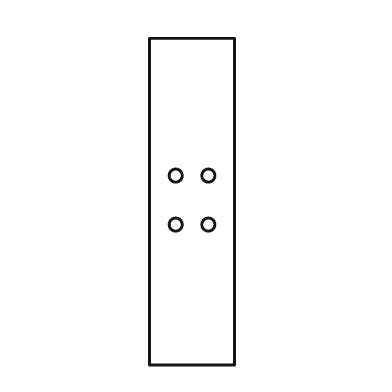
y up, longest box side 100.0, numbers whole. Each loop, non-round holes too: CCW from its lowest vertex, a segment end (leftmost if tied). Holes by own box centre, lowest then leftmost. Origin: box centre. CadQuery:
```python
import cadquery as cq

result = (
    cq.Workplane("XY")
    .moveTo(-13.0, -50.0)
    .lineTo(13.0, -50.0)
    .lineTo(13.0, 50.0)
    .lineTo(-13.0, 50.0)
    .close()
    .moveTo(-5.0, -7.0)
    .circle(2.0)
    .moveTo(5.0, -7.0)
    .circle(2.0)
    .moveTo(-5.0, 8.0)
    .circle(2.0)
    .moveTo(5.0, 8.0)
    .circle(2.0)
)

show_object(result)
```